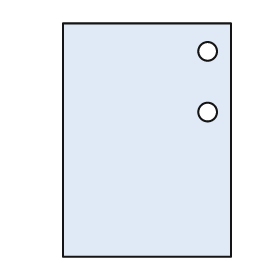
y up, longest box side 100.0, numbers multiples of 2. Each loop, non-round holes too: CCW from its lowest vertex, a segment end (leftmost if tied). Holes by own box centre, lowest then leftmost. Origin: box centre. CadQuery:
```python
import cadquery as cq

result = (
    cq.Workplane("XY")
    .moveTo(-36.0, -50.0)
    .lineTo(36.0, -50.0)
    .lineTo(36.0, 50.0)
    .lineTo(-36.0, 50.0)
    .close()
    .moveTo(26.0, 12.0)
    .circle(4.0)
    .moveTo(26.0, 38.0)
    .circle(4.0)
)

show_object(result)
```